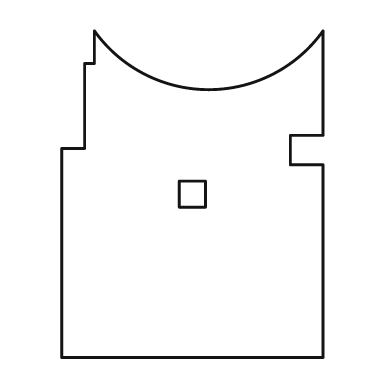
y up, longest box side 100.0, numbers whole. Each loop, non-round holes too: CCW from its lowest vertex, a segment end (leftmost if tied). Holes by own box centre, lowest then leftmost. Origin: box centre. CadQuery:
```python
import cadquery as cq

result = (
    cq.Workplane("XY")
    .moveTo(-40.0, -50.0)
    .lineTo(40.0, -50.0)
    .lineTo(40.0, 9.0)
    .lineTo(30.0, 9.0)
    .lineTo(30.0, 18.0)
    .lineTo(40.0, 18.0)
    .lineTo(40.0, 50.0)
    .threePointArc((5.0, 32.0), (-30.0, 50.0))
    .lineTo(-30.0, 40.0)
    .lineTo(-33.0, 40.0)
    .lineTo(-33.0, 14.0)
    .lineTo(-40.0, 14.0)
    .close()
    .moveTo(-4.0, -4.0)
    .lineTo(4.0, -4.0)
    .lineTo(4.0, 4.0)
    .lineTo(-4.0, 4.0)
    .close()
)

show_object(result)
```